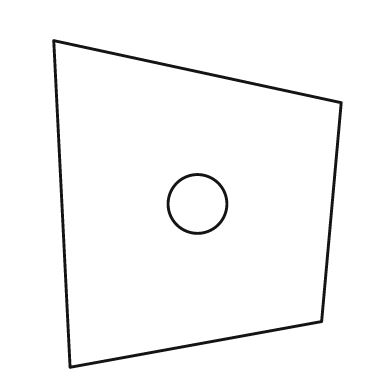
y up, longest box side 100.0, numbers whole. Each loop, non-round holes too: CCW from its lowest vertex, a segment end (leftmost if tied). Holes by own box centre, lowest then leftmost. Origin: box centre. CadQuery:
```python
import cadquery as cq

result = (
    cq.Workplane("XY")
    .moveTo(-39.0, -50.0)
    .lineTo(38.0, -36.0)
    .lineTo(44.0, 31.0)
    .lineTo(-44.0, 50.0)
    .close()
    .moveTo(0.0, 0.0)
    .circle(9.0)
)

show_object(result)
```